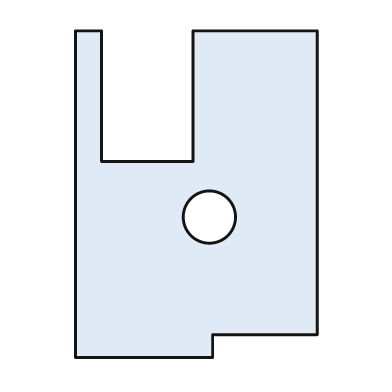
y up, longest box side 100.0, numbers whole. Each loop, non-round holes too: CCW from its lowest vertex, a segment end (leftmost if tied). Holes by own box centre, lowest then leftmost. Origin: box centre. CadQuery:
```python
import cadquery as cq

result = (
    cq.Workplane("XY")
    .moveTo(-37.0, -50.0)
    .lineTo(5.0, -50.0)
    .lineTo(5.0, -43.0)
    .lineTo(37.0, -43.0)
    .lineTo(37.0, 50.0)
    .lineTo(-1.0, 50.0)
    .lineTo(-1.0, 10.0)
    .lineTo(-29.0, 10.0)
    .lineTo(-29.0, 50.0)
    .lineTo(-37.0, 50.0)
    .close()
    .moveTo(4.0, -7.0)
    .circle(8.0)
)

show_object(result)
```